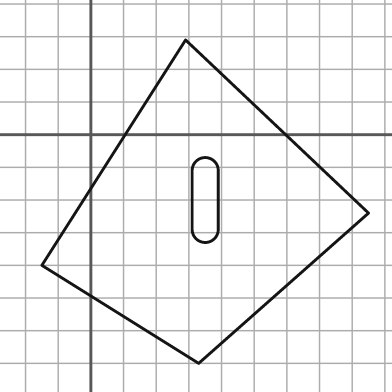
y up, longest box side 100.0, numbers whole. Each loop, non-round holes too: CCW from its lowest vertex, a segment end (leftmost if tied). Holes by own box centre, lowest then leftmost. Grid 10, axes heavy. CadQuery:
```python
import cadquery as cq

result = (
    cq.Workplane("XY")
    .moveTo(33.0, -70.0)
    .lineTo(85.0, -24.0)
    .lineTo(29.0, 29.0)
    .lineTo(-15.0, -40.0)
    .close()
    .moveTo(31.0, -29.0)
    .threePointArc((35.0, -33.0), (39.0, -29.0))
    .lineTo(39.0, -11.0)
    .threePointArc((35.0, -7.0), (31.0, -11.0))
    .close()
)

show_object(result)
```